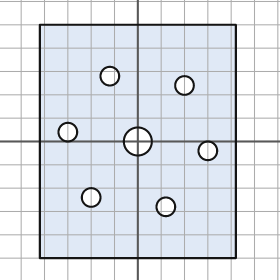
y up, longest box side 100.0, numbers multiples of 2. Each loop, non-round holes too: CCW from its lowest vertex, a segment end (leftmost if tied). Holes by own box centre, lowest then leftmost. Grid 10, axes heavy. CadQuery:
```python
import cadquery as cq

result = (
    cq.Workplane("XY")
    .moveTo(-42.0, -50.0)
    .lineTo(42.0, -50.0)
    .lineTo(42.0, 50.0)
    .lineTo(-42.0, 50.0)
    .close()
    .moveTo(12.0, -28.0)
    .circle(4.0)
    .moveTo(-20.0, -24.0)
    .circle(4.0)
    .moveTo(30.0, -4.0)
    .circle(4.0)
    .moveTo(0.0, 0.0)
    .circle(6.0)
    .moveTo(-30.0, 4.0)
    .circle(4.0)
    .moveTo(20.0, 24.0)
    .circle(4.0)
    .moveTo(-12.0, 28.0)
    .circle(4.0)
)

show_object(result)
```